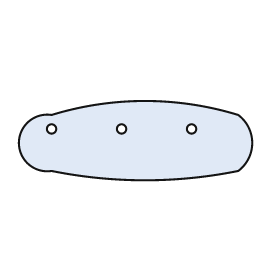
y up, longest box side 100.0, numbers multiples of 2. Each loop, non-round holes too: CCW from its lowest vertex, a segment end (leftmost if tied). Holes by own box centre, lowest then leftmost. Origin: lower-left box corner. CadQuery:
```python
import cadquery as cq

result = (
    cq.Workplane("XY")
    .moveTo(14.0, 4.0)
    .threePointArc((54.0, 0.0), (94.0, 4.0))
    .threePointArc((100.0, 16.0), (94.0, 28.0))
    .threePointArc((54.0, 34.0), (14.0, 28.0))
    .threePointArc((0.0, 16.0), (14.0, 4.0))
    .close()
    .moveTo(14.0, 22.0)
    .circle(2.0)
    .moveTo(44.0, 22.0)
    .circle(2.0)
    .moveTo(74.0, 22.0)
    .circle(2.0)
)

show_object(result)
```